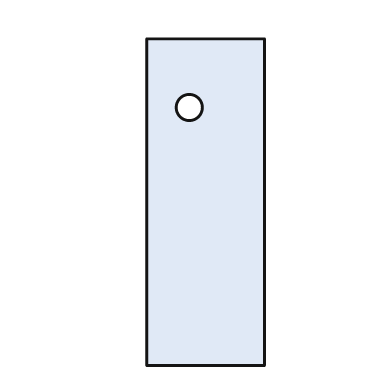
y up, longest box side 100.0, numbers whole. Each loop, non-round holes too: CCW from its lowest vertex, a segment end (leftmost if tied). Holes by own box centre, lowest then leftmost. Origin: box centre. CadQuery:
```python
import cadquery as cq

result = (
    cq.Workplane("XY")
    .moveTo(-18.0, -50.0)
    .lineTo(18.0, -50.0)
    .lineTo(18.0, 50.0)
    .lineTo(-18.0, 50.0)
    .close()
    .moveTo(-5.0, 29.0)
    .circle(4.0)
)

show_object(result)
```